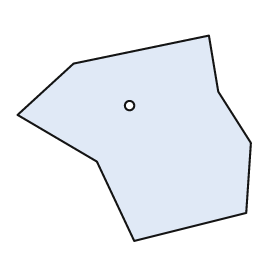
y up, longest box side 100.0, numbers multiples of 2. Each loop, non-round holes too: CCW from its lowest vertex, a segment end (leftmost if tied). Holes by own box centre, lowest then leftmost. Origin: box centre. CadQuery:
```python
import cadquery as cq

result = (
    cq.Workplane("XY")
    .moveTo(0.0, -44.0)
    .lineTo(48.0, -32.0)
    .lineTo(50.0, -2.0)
    .lineTo(36.0, 20.0)
    .lineTo(32.0, 44.0)
    .lineTo(-26.0, 32.0)
    .lineTo(-50.0, 10.0)
    .lineTo(-16.0, -10.0)
    .close()
    .moveTo(-2.0, 14.0)
    .circle(2.0)
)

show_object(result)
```